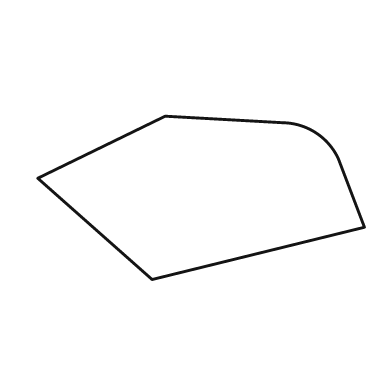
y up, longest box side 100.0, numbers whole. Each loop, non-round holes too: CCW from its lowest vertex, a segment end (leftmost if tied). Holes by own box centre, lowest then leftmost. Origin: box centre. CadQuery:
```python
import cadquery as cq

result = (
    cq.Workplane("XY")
    .moveTo(-15.0, -25.0)
    .lineTo(50.0, -9.0)
    .lineTo(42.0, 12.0)
    .threePointArc((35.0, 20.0), (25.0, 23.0))
    .lineTo(-11.0, 25.0)
    .lineTo(-50.0, 6.0)
    .close()
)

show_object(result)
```